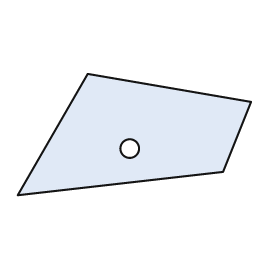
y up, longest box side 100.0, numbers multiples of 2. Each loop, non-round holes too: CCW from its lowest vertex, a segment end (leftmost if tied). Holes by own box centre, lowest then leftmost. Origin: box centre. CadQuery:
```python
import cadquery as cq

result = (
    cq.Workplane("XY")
    .moveTo(-50.0, -26.0)
    .lineTo(38.0, -16.0)
    .lineTo(50.0, 14.0)
    .lineTo(-20.0, 26.0)
    .close()
    .moveTo(-2.0, -6.0)
    .circle(4.0)
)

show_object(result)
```